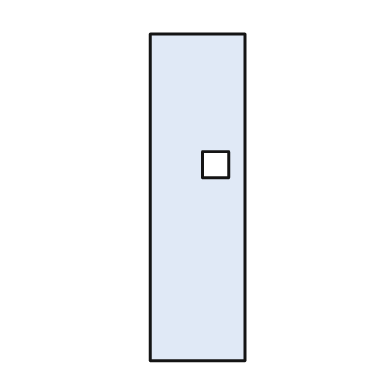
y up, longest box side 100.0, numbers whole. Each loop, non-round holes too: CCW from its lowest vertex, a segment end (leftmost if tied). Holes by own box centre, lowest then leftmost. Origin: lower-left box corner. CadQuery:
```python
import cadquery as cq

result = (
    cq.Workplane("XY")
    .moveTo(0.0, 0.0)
    .lineTo(29.0, 0.0)
    .lineTo(29.0, 100.0)
    .lineTo(0.0, 100.0)
    .close()
    .moveTo(16.0, 56.0)
    .lineTo(24.0, 56.0)
    .lineTo(24.0, 64.0)
    .lineTo(16.0, 64.0)
    .close()
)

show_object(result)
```